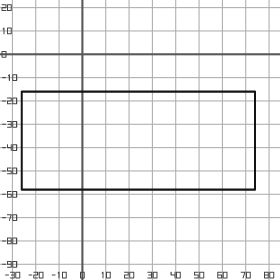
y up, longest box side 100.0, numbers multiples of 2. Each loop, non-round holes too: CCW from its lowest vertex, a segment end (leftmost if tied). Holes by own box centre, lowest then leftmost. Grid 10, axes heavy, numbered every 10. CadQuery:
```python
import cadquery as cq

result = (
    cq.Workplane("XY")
    .moveTo(-26.0, -58.0)
    .lineTo(74.0, -58.0)
    .lineTo(74.0, -16.0)
    .lineTo(-26.0, -16.0)
    .close()
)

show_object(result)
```